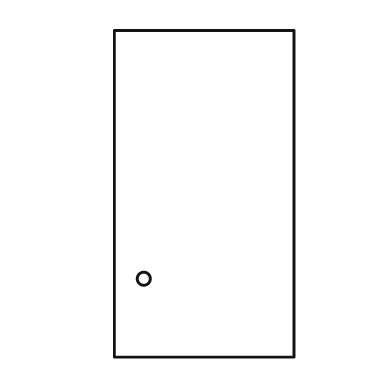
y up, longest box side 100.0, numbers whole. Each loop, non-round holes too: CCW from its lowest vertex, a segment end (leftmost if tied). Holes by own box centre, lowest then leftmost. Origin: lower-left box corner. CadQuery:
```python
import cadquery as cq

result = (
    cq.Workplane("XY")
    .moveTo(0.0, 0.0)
    .lineTo(55.0, 0.0)
    .lineTo(55.0, 100.0)
    .lineTo(0.0, 100.0)
    .close()
    .moveTo(9.0, 24.0)
    .circle(2.0)
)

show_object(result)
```